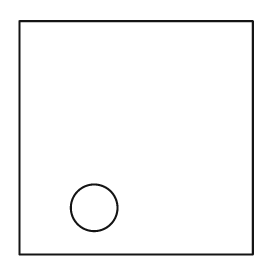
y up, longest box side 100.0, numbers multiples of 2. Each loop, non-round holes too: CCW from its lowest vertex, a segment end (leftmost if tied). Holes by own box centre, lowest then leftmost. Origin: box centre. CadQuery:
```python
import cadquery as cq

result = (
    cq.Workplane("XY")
    .moveTo(-50.0, -50.0)
    .lineTo(50.0, -50.0)
    .lineTo(50.0, 50.0)
    .lineTo(-50.0, 50.0)
    .close()
    .moveTo(-18.0, -30.0)
    .circle(10.0)
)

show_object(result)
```